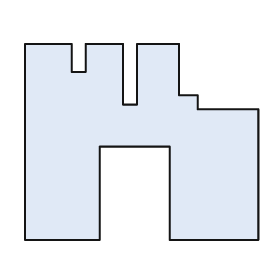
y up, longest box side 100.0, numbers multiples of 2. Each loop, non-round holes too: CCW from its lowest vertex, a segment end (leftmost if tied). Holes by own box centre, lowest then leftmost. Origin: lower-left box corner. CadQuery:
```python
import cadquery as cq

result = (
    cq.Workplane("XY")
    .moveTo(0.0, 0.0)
    .lineTo(32.0, 0.0)
    .lineTo(32.0, 40.0)
    .lineTo(62.0, 40.0)
    .lineTo(62.0, 0.0)
    .lineTo(100.0, 0.0)
    .lineTo(100.0, 56.0)
    .lineTo(74.0, 56.0)
    .lineTo(74.0, 62.0)
    .lineTo(66.0, 62.0)
    .lineTo(66.0, 84.0)
    .lineTo(48.0, 84.0)
    .lineTo(48.0, 58.0)
    .lineTo(42.0, 58.0)
    .lineTo(42.0, 84.0)
    .lineTo(26.0, 84.0)
    .lineTo(26.0, 72.0)
    .lineTo(20.0, 72.0)
    .lineTo(20.0, 84.0)
    .lineTo(0.0, 84.0)
    .close()
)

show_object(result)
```